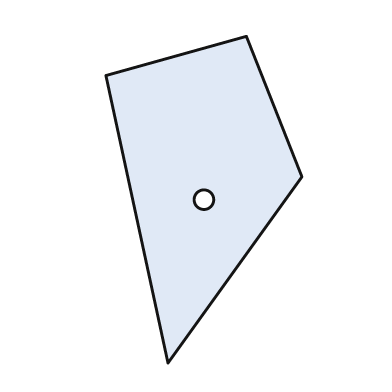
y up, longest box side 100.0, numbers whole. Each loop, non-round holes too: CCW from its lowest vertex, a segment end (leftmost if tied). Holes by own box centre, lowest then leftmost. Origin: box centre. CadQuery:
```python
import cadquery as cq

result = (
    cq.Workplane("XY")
    .moveTo(-11.0, -50.0)
    .lineTo(30.0, 7.0)
    .lineTo(13.0, 50.0)
    .lineTo(-30.0, 38.0)
    .close()
    .moveTo(0.0, 0.0)
    .circle(3.0)
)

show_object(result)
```